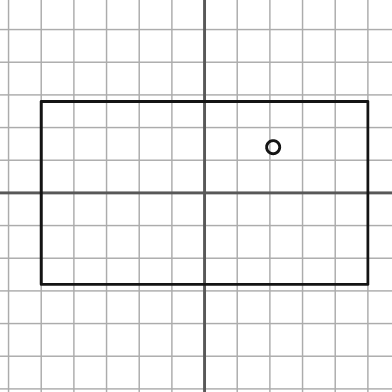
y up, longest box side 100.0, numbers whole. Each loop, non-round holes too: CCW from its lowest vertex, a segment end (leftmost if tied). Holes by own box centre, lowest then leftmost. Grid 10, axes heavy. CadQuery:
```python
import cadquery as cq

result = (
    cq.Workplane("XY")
    .moveTo(-50.0, -28.0)
    .lineTo(50.0, -28.0)
    .lineTo(50.0, 28.0)
    .lineTo(-50.0, 28.0)
    .close()
    .moveTo(21.0, 14.0)
    .circle(2.0)
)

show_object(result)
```